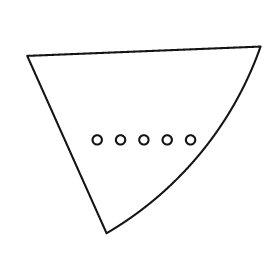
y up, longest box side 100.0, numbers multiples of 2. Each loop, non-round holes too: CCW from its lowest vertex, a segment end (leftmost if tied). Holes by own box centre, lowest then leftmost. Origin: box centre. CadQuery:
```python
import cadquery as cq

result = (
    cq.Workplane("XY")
    .moveTo(-16.0, -40.0)
    .threePointArc((24.0, -6.0), (50.0, 40.0))
    .lineTo(-50.0, 36.0)
    .close()
    .moveTo(-20.0, 0.0)
    .circle(2.0)
    .moveTo(-10.0, 0.0)
    .circle(2.0)
    .moveTo(0.0, 0.0)
    .circle(2.0)
    .moveTo(10.0, 0.0)
    .circle(2.0)
    .moveTo(20.0, 0.0)
    .circle(2.0)
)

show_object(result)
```